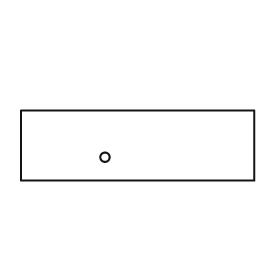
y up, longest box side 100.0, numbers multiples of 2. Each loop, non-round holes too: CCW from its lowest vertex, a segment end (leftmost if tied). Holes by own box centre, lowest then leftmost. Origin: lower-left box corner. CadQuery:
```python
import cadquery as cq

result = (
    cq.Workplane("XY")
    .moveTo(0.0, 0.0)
    .lineTo(100.0, 0.0)
    .lineTo(100.0, 30.0)
    .lineTo(0.0, 30.0)
    .close()
    .moveTo(36.0, 10.0)
    .circle(2.0)
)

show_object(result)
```